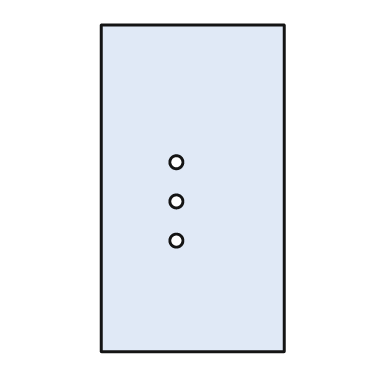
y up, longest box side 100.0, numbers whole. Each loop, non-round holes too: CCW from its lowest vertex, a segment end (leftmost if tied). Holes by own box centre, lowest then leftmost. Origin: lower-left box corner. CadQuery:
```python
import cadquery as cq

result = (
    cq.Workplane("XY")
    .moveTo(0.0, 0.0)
    .lineTo(56.0, 0.0)
    .lineTo(56.0, 100.0)
    .lineTo(0.0, 100.0)
    .close()
    .moveTo(23.0, 34.0)
    .circle(2.0)
    .moveTo(23.0, 46.0)
    .circle(2.0)
    .moveTo(23.0, 58.0)
    .circle(2.0)
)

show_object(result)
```